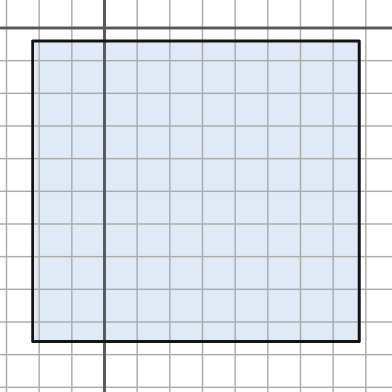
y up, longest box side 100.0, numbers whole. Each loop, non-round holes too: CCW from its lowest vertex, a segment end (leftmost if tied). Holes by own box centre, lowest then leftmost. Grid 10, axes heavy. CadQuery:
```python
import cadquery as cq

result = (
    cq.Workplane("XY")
    .moveTo(-22.0, -96.0)
    .lineTo(78.0, -96.0)
    .lineTo(78.0, -4.0)
    .lineTo(-22.0, -4.0)
    .close()
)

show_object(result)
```